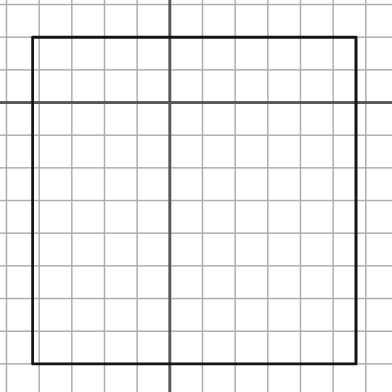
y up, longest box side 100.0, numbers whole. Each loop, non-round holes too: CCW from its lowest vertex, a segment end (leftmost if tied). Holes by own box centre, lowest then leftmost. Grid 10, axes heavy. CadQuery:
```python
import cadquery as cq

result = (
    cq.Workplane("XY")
    .moveTo(-42.0, -80.0)
    .lineTo(57.0, -80.0)
    .lineTo(57.0, 20.0)
    .lineTo(-42.0, 20.0)
    .close()
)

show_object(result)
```